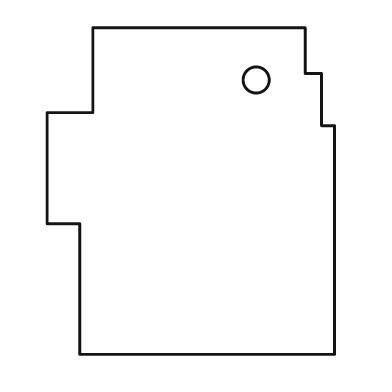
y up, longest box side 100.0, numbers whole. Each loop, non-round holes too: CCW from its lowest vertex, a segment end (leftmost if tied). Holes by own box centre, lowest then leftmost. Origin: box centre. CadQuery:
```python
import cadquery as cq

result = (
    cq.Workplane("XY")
    .moveTo(-34.0, -50.0)
    .lineTo(44.0, -50.0)
    .lineTo(44.0, 20.0)
    .lineTo(40.0, 20.0)
    .lineTo(40.0, 36.0)
    .lineTo(35.0, 36.0)
    .lineTo(35.0, 50.0)
    .lineTo(-30.0, 50.0)
    .lineTo(-30.0, 24.0)
    .lineTo(-44.0, 24.0)
    .lineTo(-44.0, -10.0)
    .lineTo(-34.0, -10.0)
    .close()
    .moveTo(20.0, 34.0)
    .circle(4.0)
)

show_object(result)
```